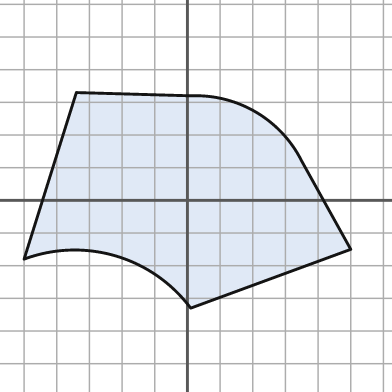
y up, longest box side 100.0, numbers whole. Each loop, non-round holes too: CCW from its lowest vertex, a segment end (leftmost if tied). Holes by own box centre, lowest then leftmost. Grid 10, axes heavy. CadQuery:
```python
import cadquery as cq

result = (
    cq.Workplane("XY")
    .moveTo(1.0, -33.0)
    .lineTo(50.0, -15.0)
    .lineTo(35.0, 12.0)
    .threePointArc((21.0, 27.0), (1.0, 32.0))
    .lineTo(-34.0, 33.0)
    .lineTo(-50.0, -18.0)
    .threePointArc((-22.0, -17.0), (1.0, -33.0))
    .close()
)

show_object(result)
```